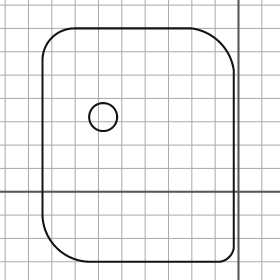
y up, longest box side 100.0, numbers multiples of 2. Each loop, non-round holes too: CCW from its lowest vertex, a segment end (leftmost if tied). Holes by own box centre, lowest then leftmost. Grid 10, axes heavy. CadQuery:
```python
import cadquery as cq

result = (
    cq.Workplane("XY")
    .moveTo(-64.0, -30.0)
    .lineTo(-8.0, -30.0)
    .threePointArc((-4.0, -28.0), (-2.0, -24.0))
    .lineTo(-2.0, 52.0)
    .threePointArc((-8.0, 64.0), (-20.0, 70.0))
    .lineTo(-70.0, 70.0)
    .threePointArc((-80.0, 66.0), (-84.0, 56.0))
    .lineTo(-84.0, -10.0)
    .threePointArc((-78.0, -24.0), (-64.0, -30.0))
    .close()
    .moveTo(-58.0, 32.0)
    .circle(6.0)
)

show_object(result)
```